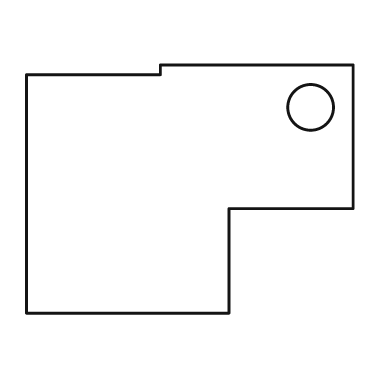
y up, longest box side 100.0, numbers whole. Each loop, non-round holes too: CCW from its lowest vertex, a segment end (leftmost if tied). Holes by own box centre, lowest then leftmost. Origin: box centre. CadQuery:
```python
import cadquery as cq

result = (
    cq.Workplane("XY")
    .moveTo(-50.0, -38.0)
    .lineTo(12.0, -38.0)
    .lineTo(12.0, -6.0)
    .lineTo(50.0, -6.0)
    .lineTo(50.0, 38.0)
    .lineTo(-9.0, 38.0)
    .lineTo(-9.0, 35.0)
    .lineTo(-50.0, 35.0)
    .close()
    .moveTo(37.0, 25.0)
    .circle(7.0)
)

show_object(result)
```